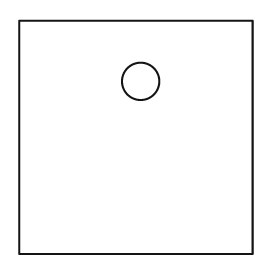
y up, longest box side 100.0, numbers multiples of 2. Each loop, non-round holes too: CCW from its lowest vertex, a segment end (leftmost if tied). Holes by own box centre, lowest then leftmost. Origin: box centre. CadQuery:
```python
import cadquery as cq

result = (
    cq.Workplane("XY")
    .moveTo(-50.0, -50.0)
    .lineTo(50.0, -50.0)
    .lineTo(50.0, 50.0)
    .lineTo(-50.0, 50.0)
    .close()
    .moveTo(2.0, 24.0)
    .circle(8.0)
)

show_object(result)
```